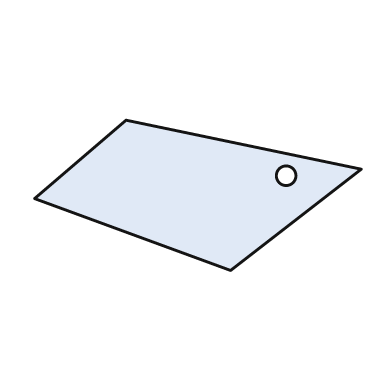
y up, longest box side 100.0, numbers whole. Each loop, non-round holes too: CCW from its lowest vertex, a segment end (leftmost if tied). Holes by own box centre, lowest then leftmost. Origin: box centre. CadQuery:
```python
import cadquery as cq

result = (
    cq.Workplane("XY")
    .moveTo(10.0, -23.0)
    .lineTo(50.0, 8.0)
    .lineTo(-22.0, 23.0)
    .lineTo(-50.0, -1.0)
    .close()
    .moveTo(27.0, 6.0)
    .circle(3.0)
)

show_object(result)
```